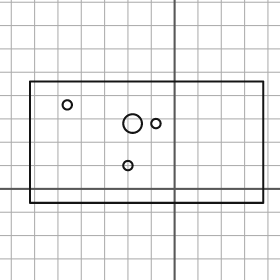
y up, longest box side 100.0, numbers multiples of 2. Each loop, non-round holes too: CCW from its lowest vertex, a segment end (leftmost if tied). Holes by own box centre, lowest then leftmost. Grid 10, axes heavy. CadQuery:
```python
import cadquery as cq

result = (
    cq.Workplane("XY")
    .moveTo(-62.0, -6.0)
    .lineTo(38.0, -6.0)
    .lineTo(38.0, 46.0)
    .lineTo(-62.0, 46.0)
    .close()
    .moveTo(-20.0, 10.0)
    .circle(2.0)
    .moveTo(-18.0, 28.0)
    .circle(4.0)
    .moveTo(-8.0, 28.0)
    .circle(2.0)
    .moveTo(-46.0, 36.0)
    .circle(2.0)
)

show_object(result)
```